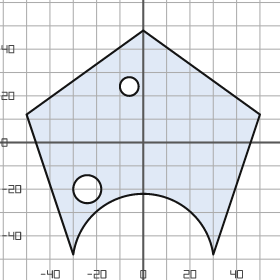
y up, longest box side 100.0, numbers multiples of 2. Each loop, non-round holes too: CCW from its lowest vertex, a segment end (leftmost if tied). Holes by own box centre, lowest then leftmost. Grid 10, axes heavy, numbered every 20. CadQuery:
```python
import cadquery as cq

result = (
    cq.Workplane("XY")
    .moveTo(-30.0, -48.0)
    .threePointArc((0.0, -22.0), (30.0, -48.0))
    .lineTo(50.0, 12.0)
    .lineTo(0.0, 48.0)
    .lineTo(-50.0, 12.0)
    .close()
    .moveTo(-24.0, -20.0)
    .circle(6.0)
    .moveTo(-6.0, 24.0)
    .circle(4.0)
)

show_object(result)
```